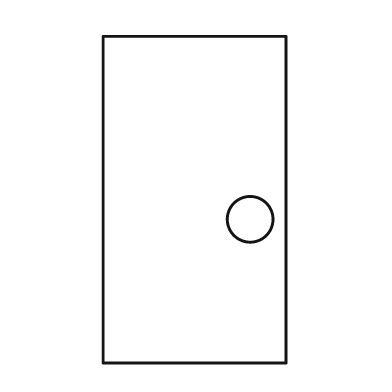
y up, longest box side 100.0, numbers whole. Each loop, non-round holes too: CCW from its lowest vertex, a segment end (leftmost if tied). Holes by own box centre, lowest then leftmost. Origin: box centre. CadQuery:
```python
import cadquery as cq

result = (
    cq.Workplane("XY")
    .moveTo(-28.0, -50.0)
    .lineTo(28.0, -50.0)
    .lineTo(28.0, 50.0)
    .lineTo(-28.0, 50.0)
    .close()
    .moveTo(17.0, -6.0)
    .circle(7.0)
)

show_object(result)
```